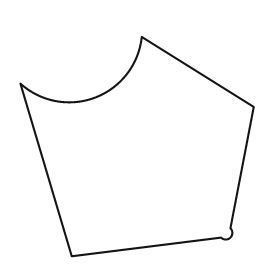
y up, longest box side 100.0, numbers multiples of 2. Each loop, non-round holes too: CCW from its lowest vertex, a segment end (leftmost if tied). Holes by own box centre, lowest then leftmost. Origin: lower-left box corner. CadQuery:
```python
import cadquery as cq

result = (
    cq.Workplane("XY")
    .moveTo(22.0, 0.0)
    .lineTo(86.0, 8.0)
    .threePointArc((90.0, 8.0), (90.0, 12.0))
    .lineTo(100.0, 64.0)
    .lineTo(52.0, 94.0)
    .threePointArc((32.0, 68.0), (0.0, 74.0))
    .close()
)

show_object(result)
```